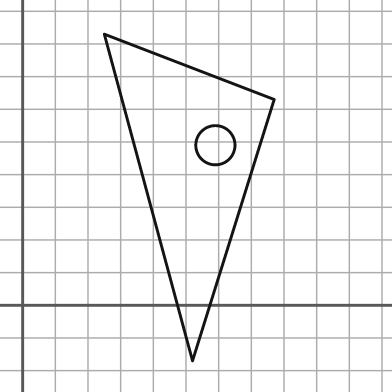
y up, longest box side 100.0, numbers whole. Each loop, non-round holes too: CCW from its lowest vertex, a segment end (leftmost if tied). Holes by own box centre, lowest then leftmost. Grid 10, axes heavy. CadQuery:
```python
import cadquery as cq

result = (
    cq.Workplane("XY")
    .moveTo(52.0, -17.0)
    .lineTo(77.0, 63.0)
    .lineTo(25.0, 83.0)
    .close()
    .moveTo(59.0, 49.0)
    .circle(6.0)
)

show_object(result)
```